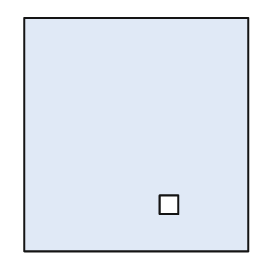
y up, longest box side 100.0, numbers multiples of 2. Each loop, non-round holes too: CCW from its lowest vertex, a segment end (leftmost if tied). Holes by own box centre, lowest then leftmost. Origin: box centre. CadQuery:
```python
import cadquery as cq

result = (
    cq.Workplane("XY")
    .moveTo(-48.0, -50.0)
    .lineTo(48.0, -50.0)
    .lineTo(48.0, 50.0)
    .lineTo(-48.0, 50.0)
    .close()
    .moveTo(10.0, -34.0)
    .lineTo(18.0, -34.0)
    .lineTo(18.0, -26.0)
    .lineTo(10.0, -26.0)
    .close()
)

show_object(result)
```